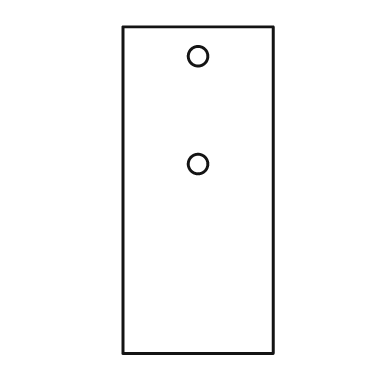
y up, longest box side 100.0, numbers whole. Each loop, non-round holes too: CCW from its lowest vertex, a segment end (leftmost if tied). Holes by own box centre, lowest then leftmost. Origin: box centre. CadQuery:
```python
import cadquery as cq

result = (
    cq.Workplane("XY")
    .moveTo(-23.0, -50.0)
    .lineTo(23.0, -50.0)
    .lineTo(23.0, 50.0)
    .lineTo(-23.0, 50.0)
    .close()
    .moveTo(0.0, 8.0)
    .circle(3.0)
    .moveTo(0.0, 41.0)
    .circle(3.0)
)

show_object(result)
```